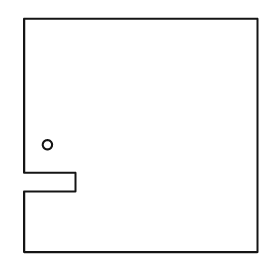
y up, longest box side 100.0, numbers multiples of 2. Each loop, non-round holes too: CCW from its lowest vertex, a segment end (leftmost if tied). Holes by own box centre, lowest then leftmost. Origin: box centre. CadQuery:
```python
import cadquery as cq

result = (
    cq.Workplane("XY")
    .moveTo(-50.0, -50.0)
    .lineTo(50.0, -50.0)
    .lineTo(50.0, 50.0)
    .lineTo(-50.0, 50.0)
    .lineTo(-50.0, -16.0)
    .lineTo(-28.0, -16.0)
    .lineTo(-28.0, -24.0)
    .lineTo(-50.0, -24.0)
    .close()
    .moveTo(-40.0, -4.0)
    .circle(2.0)
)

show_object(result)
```